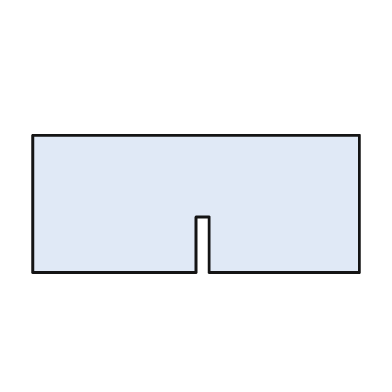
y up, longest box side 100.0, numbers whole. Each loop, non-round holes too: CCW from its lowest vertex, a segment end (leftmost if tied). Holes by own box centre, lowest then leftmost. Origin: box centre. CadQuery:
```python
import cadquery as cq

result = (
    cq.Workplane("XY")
    .moveTo(-50.0, -21.0)
    .lineTo(0.0, -21.0)
    .lineTo(0.0, -4.0)
    .lineTo(4.0, -4.0)
    .lineTo(4.0, -21.0)
    .lineTo(50.0, -21.0)
    .lineTo(50.0, 21.0)
    .lineTo(-50.0, 21.0)
    .close()
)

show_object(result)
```